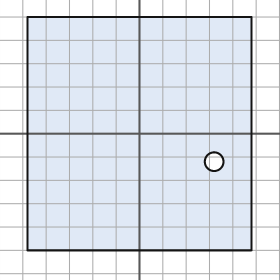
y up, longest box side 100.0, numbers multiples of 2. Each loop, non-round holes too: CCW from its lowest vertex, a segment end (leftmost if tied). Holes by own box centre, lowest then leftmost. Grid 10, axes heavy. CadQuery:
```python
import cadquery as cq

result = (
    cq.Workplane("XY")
    .moveTo(-48.0, -50.0)
    .lineTo(48.0, -50.0)
    .lineTo(48.0, 50.0)
    .lineTo(-48.0, 50.0)
    .close()
    .moveTo(32.0, -12.0)
    .circle(4.0)
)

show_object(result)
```